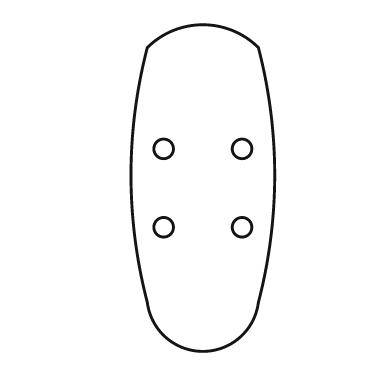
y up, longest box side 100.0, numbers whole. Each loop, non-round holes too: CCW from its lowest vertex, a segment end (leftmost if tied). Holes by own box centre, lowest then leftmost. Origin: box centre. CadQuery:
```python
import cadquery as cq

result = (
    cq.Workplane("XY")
    .moveTo(-17.0, -35.0)
    .threePointArc((0.0, -50.0), (17.0, -35.0))
    .threePointArc((22.0, 4.0), (17.0, 43.0))
    .threePointArc((0.0, 50.0), (-17.0, 43.0))
    .threePointArc((-22.0, 4.0), (-17.0, -35.0))
    .close()
    .moveTo(-12.0, -12.0)
    .circle(3.0)
    .moveTo(12.0, -12.0)
    .circle(3.0)
    .moveTo(-12.0, 12.0)
    .circle(3.0)
    .moveTo(12.0, 12.0)
    .circle(3.0)
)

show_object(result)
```